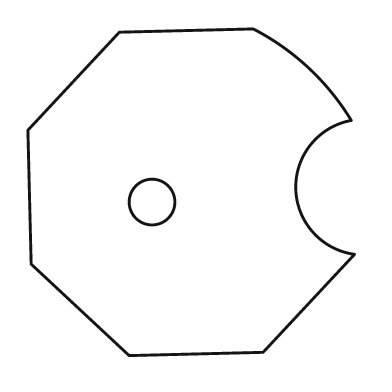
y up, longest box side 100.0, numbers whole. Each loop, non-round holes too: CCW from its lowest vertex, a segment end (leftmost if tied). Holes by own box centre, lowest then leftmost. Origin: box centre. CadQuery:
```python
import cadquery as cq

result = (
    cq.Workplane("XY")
    .moveTo(-19.0, -50.0)
    .lineTo(22.0, -49.0)
    .lineTo(50.0, -19.0)
    .threePointArc((32.0, 1.0), (49.0, 22.0))
    .threePointArc((36.0, 38.0), (19.0, 50.0))
    .lineTo(-22.0, 49.0)
    .lineTo(-50.0, 19.0)
    .lineTo(-49.0, -22.0)
    .close()
    .moveTo(-12.0, -3.0)
    .circle(7.0)
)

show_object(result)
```